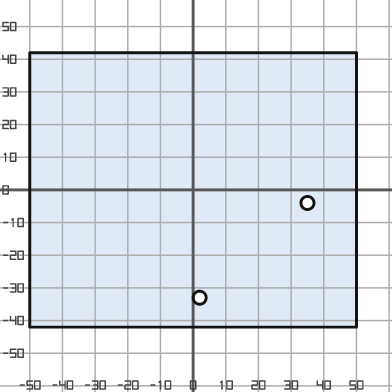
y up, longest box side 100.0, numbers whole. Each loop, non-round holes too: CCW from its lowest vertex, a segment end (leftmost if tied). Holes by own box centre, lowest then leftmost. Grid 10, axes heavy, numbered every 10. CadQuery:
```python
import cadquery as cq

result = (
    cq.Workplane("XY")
    .moveTo(-50.0, -42.0)
    .lineTo(50.0, -42.0)
    .lineTo(50.0, 42.0)
    .lineTo(-50.0, 42.0)
    .close()
    .moveTo(2.0, -33.0)
    .circle(2.0)
    .moveTo(35.0, -4.0)
    .circle(2.0)
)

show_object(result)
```